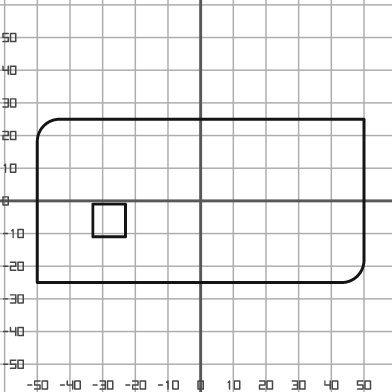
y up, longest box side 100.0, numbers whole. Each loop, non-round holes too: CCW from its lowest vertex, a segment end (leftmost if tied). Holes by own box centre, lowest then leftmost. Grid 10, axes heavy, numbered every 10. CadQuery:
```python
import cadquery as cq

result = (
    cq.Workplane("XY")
    .moveTo(-50.0, -25.0)
    .lineTo(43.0, -25.0)
    .threePointArc((48.0, -23.0), (50.0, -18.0))
    .lineTo(50.0, 25.0)
    .lineTo(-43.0, 25.0)
    .threePointArc((-48.0, 23.0), (-50.0, 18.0))
    .close()
    .moveTo(-33.0, -11.0)
    .lineTo(-23.0, -11.0)
    .lineTo(-23.0, -1.0)
    .lineTo(-33.0, -1.0)
    .close()
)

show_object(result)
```